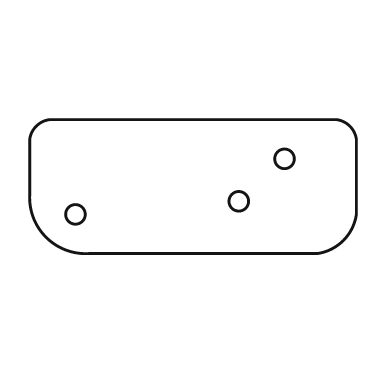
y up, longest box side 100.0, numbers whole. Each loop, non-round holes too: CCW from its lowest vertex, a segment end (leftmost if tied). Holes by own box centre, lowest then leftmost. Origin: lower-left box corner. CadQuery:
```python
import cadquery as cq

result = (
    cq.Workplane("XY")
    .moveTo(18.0, 0.0)
    .lineTo(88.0, 0.0)
    .threePointArc((96.0, 4.0), (100.0, 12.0))
    .lineTo(100.0, 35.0)
    .threePointArc((98.0, 39.0), (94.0, 41.0))
    .lineTo(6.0, 41.0)
    .threePointArc((2.0, 39.0), (0.0, 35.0))
    .lineTo(0.0, 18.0)
    .threePointArc((5.0, 5.0), (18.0, 0.0))
    .close()
    .moveTo(14.0, 12.0)
    .circle(3.0)
    .moveTo(64.0, 16.0)
    .circle(3.0)
    .moveTo(78.0, 29.0)
    .circle(3.0)
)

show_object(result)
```